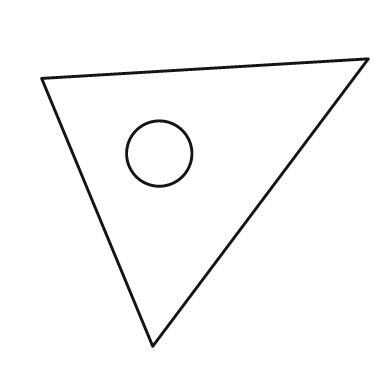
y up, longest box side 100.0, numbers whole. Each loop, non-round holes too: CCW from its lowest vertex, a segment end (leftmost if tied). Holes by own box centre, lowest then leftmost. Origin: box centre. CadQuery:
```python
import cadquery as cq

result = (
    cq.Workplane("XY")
    .moveTo(-16.0, -44.0)
    .lineTo(50.0, 44.0)
    .lineTo(-50.0, 38.0)
    .close()
    .moveTo(-14.0, 15.0)
    .circle(10.0)
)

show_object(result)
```